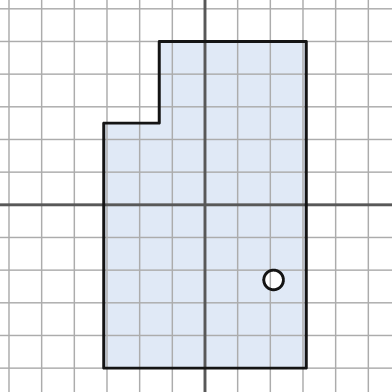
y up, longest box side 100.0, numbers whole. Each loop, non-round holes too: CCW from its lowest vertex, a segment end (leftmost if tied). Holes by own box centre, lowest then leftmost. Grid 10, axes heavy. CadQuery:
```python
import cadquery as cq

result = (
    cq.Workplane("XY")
    .moveTo(-31.0, -50.0)
    .lineTo(31.0, -50.0)
    .lineTo(31.0, 50.0)
    .lineTo(-14.0, 50.0)
    .lineTo(-14.0, 25.0)
    .lineTo(-31.0, 25.0)
    .close()
    .moveTo(21.0, -23.0)
    .circle(3.0)
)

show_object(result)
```